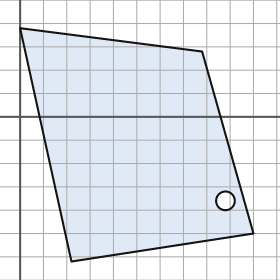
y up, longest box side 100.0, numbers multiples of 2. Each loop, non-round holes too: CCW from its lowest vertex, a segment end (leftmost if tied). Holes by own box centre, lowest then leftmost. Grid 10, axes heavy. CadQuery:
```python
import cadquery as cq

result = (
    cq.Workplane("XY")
    .moveTo(22.0, -62.0)
    .lineTo(100.0, -50.0)
    .lineTo(78.0, 28.0)
    .lineTo(0.0, 38.0)
    .close()
    .moveTo(88.0, -36.0)
    .circle(4.0)
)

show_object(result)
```